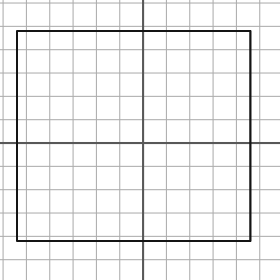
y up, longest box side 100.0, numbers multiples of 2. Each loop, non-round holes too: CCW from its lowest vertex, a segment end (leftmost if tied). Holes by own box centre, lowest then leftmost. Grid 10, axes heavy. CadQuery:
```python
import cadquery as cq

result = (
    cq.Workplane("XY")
    .moveTo(-54.0, -42.0)
    .lineTo(46.0, -42.0)
    .lineTo(46.0, 48.0)
    .lineTo(-54.0, 48.0)
    .close()
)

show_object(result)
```